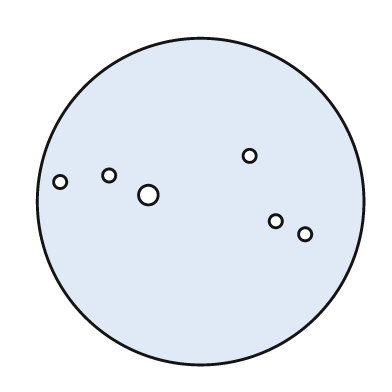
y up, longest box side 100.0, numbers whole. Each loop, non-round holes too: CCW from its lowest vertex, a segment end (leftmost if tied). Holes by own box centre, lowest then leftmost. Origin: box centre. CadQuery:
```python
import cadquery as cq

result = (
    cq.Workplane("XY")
    .moveTo(0.0, 0.0)
    .circle(50.0)
    .moveTo(32.0, -10.0)
    .circle(2.0)
    .moveTo(23.0, -6.0)
    .circle(2.0)
    .moveTo(-16.0, 2.0)
    .circle(3.0)
    .moveTo(-43.0, 6.0)
    .circle(2.0)
    .moveTo(-28.0, 8.0)
    .circle(2.0)
    .moveTo(15.0, 14.0)
    .circle(2.0)
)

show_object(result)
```